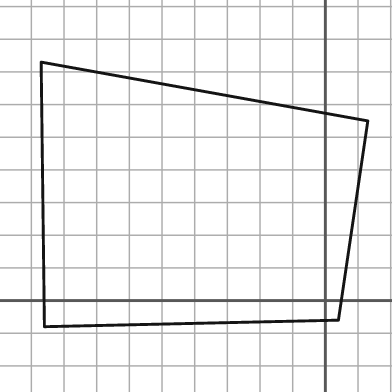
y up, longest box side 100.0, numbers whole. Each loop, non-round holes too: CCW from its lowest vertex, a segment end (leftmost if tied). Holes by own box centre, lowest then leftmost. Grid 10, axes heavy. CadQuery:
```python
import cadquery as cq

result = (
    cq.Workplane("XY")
    .moveTo(-86.0, -8.0)
    .lineTo(4.0, -6.0)
    .lineTo(13.0, 55.0)
    .lineTo(-87.0, 73.0)
    .close()
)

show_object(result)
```